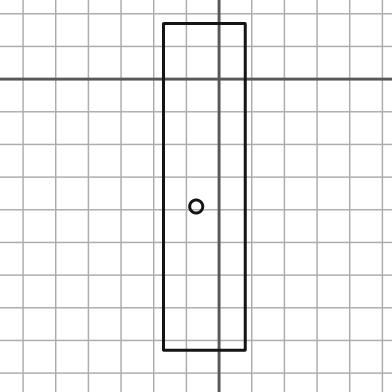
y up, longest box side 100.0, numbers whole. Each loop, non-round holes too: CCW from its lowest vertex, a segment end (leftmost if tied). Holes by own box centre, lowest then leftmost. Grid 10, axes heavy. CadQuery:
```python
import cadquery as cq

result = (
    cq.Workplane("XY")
    .moveTo(-17.0, -83.0)
    .lineTo(8.0, -83.0)
    .lineTo(8.0, 17.0)
    .lineTo(-17.0, 17.0)
    .close()
    .moveTo(-7.0, -39.0)
    .circle(2.0)
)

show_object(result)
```